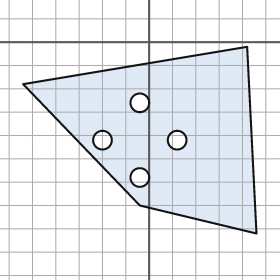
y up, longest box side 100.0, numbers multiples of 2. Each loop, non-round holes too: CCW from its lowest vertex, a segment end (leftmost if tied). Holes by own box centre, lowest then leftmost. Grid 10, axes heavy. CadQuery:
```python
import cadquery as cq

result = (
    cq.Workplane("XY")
    .moveTo(46.0, -82.0)
    .lineTo(42.0, -2.0)
    .lineTo(-54.0, -18.0)
    .lineTo(-4.0, -70.0)
    .close()
    .moveTo(-4.0, -58.0)
    .circle(4.0)
    .moveTo(-20.0, -42.0)
    .circle(4.0)
    .moveTo(12.0, -42.0)
    .circle(4.0)
    .moveTo(-4.0, -26.0)
    .circle(4.0)
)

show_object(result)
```